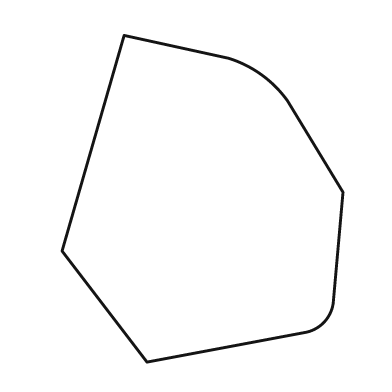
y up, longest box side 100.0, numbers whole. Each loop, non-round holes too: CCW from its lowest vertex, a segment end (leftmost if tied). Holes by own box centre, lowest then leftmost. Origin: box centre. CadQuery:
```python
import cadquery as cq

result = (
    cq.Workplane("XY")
    .moveTo(-17.0, -50.0)
    .lineTo(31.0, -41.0)
    .threePointArc((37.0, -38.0), (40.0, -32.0))
    .lineTo(43.0, 2.0)
    .lineTo(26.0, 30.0)
    .threePointArc((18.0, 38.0), (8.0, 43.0))
    .lineTo(-24.0, 50.0)
    .lineTo(-43.0, -16.0)
    .close()
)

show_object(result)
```